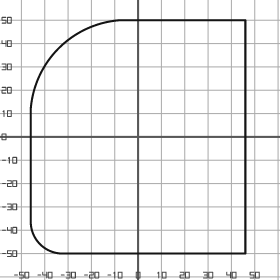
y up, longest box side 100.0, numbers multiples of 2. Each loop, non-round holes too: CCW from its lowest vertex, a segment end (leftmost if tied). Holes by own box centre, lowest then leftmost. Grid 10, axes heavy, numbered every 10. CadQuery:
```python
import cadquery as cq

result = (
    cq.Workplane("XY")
    .moveTo(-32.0, -50.0)
    .lineTo(46.0, -50.0)
    .lineTo(46.0, 50.0)
    .lineTo(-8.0, 50.0)
    .threePointArc((-34.0, 38.0), (-46.0, 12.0))
    .lineTo(-46.0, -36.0)
    .threePointArc((-42.0, -46.0), (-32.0, -50.0))
    .close()
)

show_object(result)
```